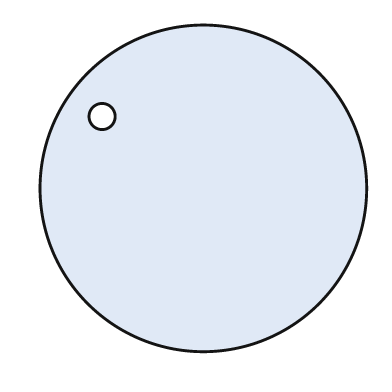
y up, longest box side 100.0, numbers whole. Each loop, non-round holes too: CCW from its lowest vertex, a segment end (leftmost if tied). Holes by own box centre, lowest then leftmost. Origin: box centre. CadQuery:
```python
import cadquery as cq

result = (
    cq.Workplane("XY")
    .moveTo(0.0, 0.0)
    .circle(50.0)
    .moveTo(-31.0, 22.0)
    .circle(4.0)
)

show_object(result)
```